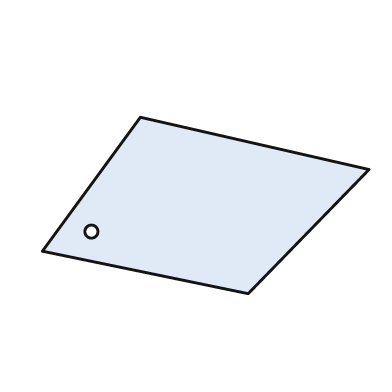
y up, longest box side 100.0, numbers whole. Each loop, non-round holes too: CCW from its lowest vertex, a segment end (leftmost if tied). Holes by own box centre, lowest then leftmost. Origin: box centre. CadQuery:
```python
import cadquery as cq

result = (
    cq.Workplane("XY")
    .moveTo(13.0, -27.0)
    .lineTo(50.0, 11.0)
    .lineTo(-20.0, 27.0)
    .lineTo(-50.0, -14.0)
    .close()
    .moveTo(-35.0, -8.0)
    .circle(2.0)
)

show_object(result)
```